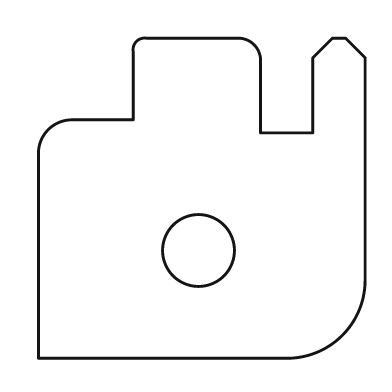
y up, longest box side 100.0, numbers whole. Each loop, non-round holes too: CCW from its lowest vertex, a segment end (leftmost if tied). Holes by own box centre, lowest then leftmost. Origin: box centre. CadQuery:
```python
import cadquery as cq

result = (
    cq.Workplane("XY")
    .moveTo(-50.0, -49.0)
    .lineTo(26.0, -49.0)
    .threePointArc((43.0, -42.0), (50.0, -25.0))
    .lineTo(50.0, 43.0)
    .lineTo(44.0, 49.0)
    .lineTo(40.0, 49.0)
    .lineTo(34.0, 43.0)
    .lineTo(34.0, 20.0)
    .lineTo(18.0, 20.0)
    .lineTo(18.0, 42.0)
    .threePointArc((16.0, 47.0), (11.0, 49.0))
    .lineTo(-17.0, 49.0)
    .threePointArc((-20.0, 48.0), (-21.0, 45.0))
    .lineTo(-21.0, 24.0)
    .lineTo(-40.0, 24.0)
    .threePointArc((-47.0, 21.0), (-50.0, 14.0))
    .close()
    .moveTo(-1.0, -16.0)
    .circle(11.0)
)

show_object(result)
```